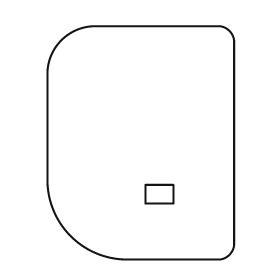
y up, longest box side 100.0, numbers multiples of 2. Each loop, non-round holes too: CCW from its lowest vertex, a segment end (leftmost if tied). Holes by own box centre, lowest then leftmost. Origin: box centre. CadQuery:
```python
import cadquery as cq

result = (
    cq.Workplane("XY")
    .moveTo(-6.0, -50.0)
    .lineTo(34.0, -50.0)
    .threePointArc((38.0, -48.0), (40.0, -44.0))
    .lineTo(40.0, 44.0)
    .threePointArc((38.0, 48.0), (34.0, 50.0))
    .lineTo(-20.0, 50.0)
    .threePointArc((-34.0, 44.0), (-40.0, 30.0))
    .lineTo(-40.0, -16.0)
    .threePointArc((-30.0, -40.0), (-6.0, -50.0))
    .close()
    .moveTo(2.0, -26.0)
    .lineTo(14.0, -26.0)
    .lineTo(14.0, -18.0)
    .lineTo(2.0, -18.0)
    .close()
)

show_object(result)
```